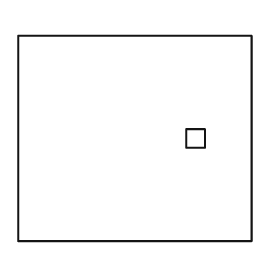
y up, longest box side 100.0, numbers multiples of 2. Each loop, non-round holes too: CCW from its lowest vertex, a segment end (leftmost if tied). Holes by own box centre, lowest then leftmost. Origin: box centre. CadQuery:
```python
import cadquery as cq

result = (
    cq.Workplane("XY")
    .moveTo(-50.0, -44.0)
    .lineTo(50.0, -44.0)
    .lineTo(50.0, 44.0)
    .lineTo(-50.0, 44.0)
    .close()
    .moveTo(22.0, -4.0)
    .lineTo(30.0, -4.0)
    .lineTo(30.0, 4.0)
    .lineTo(22.0, 4.0)
    .close()
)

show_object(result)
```